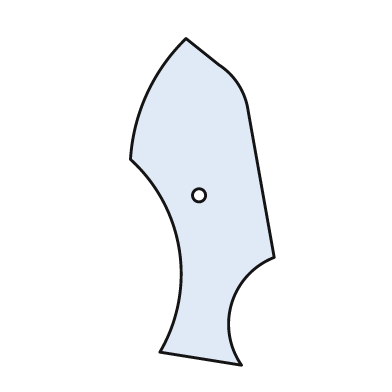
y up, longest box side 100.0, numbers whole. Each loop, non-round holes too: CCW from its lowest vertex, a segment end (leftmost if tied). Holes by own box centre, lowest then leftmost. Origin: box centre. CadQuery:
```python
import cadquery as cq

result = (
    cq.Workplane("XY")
    .moveTo(12.0, -50.0)
    .threePointArc((9.0, -31.0), (22.0, -17.0))
    .lineTo(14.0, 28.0)
    .threePointArc((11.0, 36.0), (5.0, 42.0))
    .lineTo(-5.0, 50.0)
    .threePointArc((-17.0, 33.0), (-22.0, 13.0))
    .threePointArc((-7.0, -15.0), (-13.0, -46.0))
    .close()
    .moveTo(-1.0, 2.0)
    .circle(2.0)
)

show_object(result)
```